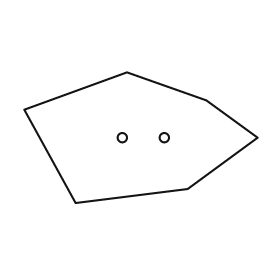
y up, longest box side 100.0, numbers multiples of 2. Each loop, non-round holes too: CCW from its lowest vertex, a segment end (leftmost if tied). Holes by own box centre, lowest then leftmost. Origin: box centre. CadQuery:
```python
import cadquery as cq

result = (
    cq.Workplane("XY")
    .moveTo(-28.0, -28.0)
    .lineTo(20.0, -22.0)
    .lineTo(50.0, 0.0)
    .lineTo(28.0, 16.0)
    .lineTo(-6.0, 28.0)
    .lineTo(-50.0, 12.0)
    .close()
    .moveTo(-8.0, 0.0)
    .circle(2.0)
    .moveTo(10.0, 0.0)
    .circle(2.0)
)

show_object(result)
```